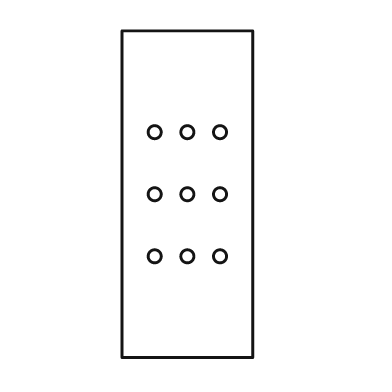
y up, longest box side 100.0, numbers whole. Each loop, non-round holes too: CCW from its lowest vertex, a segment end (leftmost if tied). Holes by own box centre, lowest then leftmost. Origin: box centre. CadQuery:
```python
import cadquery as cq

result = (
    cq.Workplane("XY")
    .moveTo(-20.0, -50.0)
    .lineTo(20.0, -50.0)
    .lineTo(20.0, 50.0)
    .lineTo(-20.0, 50.0)
    .close()
    .moveTo(-10.0, -19.0)
    .circle(2.0)
    .moveTo(0.0, -19.0)
    .circle(2.0)
    .moveTo(10.0, -19.0)
    .circle(2.0)
    .moveTo(-10.0, 0.0)
    .circle(2.0)
    .moveTo(0.0, 0.0)
    .circle(2.0)
    .moveTo(10.0, 0.0)
    .circle(2.0)
    .moveTo(-10.0, 19.0)
    .circle(2.0)
    .moveTo(0.0, 19.0)
    .circle(2.0)
    .moveTo(10.0, 19.0)
    .circle(2.0)
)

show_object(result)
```